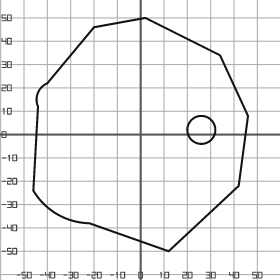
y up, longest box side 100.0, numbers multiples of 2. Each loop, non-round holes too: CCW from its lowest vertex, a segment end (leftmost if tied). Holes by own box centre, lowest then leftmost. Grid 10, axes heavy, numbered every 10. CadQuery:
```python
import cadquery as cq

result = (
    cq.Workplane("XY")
    .moveTo(12.0, -50.0)
    .lineTo(42.0, -22.0)
    .lineTo(46.0, 8.0)
    .lineTo(34.0, 34.0)
    .lineTo(2.0, 50.0)
    .lineTo(-20.0, 46.0)
    .lineTo(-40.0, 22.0)
    .threePointArc((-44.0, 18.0), (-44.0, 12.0))
    .lineTo(-46.0, -24.0)
    .threePointArc((-36.0, -34.0), (-22.0, -38.0))
    .close()
    .moveTo(26.0, 2.0)
    .circle(6.0)
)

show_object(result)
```